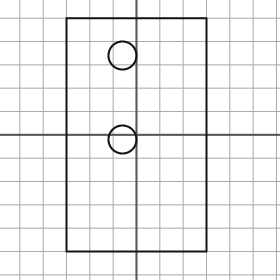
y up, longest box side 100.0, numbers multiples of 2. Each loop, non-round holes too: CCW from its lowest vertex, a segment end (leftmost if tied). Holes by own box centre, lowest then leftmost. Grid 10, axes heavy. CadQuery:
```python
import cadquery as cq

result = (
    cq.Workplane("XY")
    .moveTo(-30.0, -50.0)
    .lineTo(30.0, -50.0)
    .lineTo(30.0, 50.0)
    .lineTo(-30.0, 50.0)
    .close()
    .moveTo(-6.0, -2.0)
    .circle(6.0)
    .moveTo(-6.0, 34.0)
    .circle(6.0)
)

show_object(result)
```